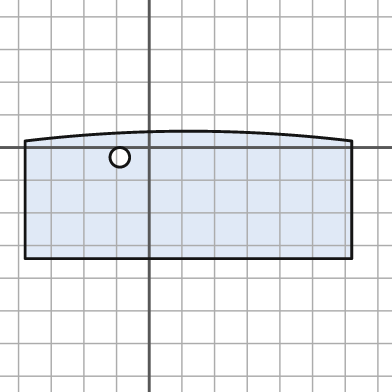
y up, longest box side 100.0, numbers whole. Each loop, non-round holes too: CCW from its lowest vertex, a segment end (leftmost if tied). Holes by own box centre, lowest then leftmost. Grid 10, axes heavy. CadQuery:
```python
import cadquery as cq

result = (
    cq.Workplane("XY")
    .moveTo(-38.0, -34.0)
    .lineTo(62.0, -34.0)
    .lineTo(62.0, 2.0)
    .threePointArc((12.0, 5.0), (-38.0, 2.0))
    .close()
    .moveTo(-9.0, -3.0)
    .circle(3.0)
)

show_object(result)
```